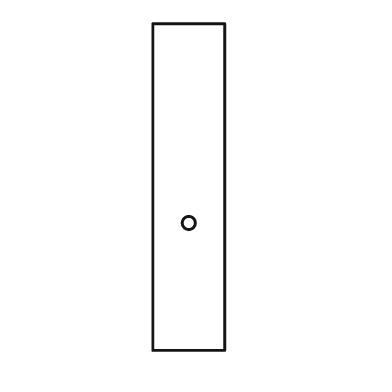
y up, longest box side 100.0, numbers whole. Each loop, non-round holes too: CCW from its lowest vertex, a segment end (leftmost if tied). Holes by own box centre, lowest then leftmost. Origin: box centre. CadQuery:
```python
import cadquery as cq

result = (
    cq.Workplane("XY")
    .moveTo(-11.0, -50.0)
    .lineTo(11.0, -50.0)
    .lineTo(11.0, 50.0)
    .lineTo(-11.0, 50.0)
    .close()
    .moveTo(0.0, -11.0)
    .circle(2.0)
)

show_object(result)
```